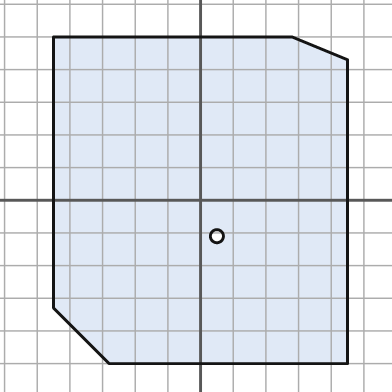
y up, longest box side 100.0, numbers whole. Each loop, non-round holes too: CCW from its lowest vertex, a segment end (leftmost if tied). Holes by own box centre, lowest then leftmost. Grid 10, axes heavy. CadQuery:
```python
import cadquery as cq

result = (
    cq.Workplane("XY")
    .moveTo(-28.0, -50.0)
    .lineTo(45.0, -50.0)
    .lineTo(45.0, 43.0)
    .lineTo(28.0, 50.0)
    .lineTo(-45.0, 50.0)
    .lineTo(-45.0, -33.0)
    .close()
    .moveTo(5.0, -11.0)
    .circle(2.0)
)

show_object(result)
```